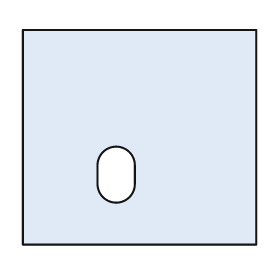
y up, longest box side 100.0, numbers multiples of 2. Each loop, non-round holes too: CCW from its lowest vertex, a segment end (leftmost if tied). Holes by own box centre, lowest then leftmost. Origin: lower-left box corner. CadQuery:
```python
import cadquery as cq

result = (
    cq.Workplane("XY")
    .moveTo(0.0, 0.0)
    .lineTo(100.0, 0.0)
    .lineTo(100.0, 92.0)
    .lineTo(0.0, 92.0)
    .close()
    .moveTo(32.0, 26.0)
    .threePointArc((40.0, 18.0), (48.0, 26.0))
    .lineTo(48.0, 34.0)
    .threePointArc((40.0, 42.0), (32.0, 34.0))
    .close()
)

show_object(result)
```